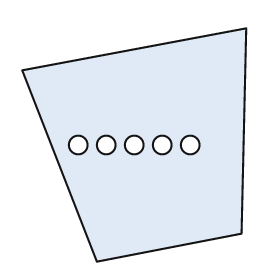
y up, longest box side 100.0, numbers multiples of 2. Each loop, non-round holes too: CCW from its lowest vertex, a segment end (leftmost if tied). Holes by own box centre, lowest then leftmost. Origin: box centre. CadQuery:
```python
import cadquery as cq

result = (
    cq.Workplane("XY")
    .moveTo(-16.0, -50.0)
    .lineTo(46.0, -38.0)
    .lineTo(48.0, 50.0)
    .lineTo(-48.0, 32.0)
    .close()
    .moveTo(-24.0, 0.0)
    .circle(4.0)
    .moveTo(-12.0, 0.0)
    .circle(4.0)
    .moveTo(0.0, 0.0)
    .circle(4.0)
    .moveTo(12.0, 0.0)
    .circle(4.0)
    .moveTo(24.0, 0.0)
    .circle(4.0)
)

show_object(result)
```